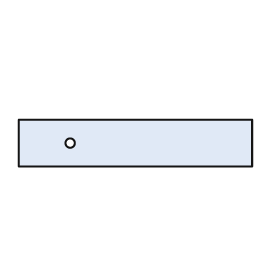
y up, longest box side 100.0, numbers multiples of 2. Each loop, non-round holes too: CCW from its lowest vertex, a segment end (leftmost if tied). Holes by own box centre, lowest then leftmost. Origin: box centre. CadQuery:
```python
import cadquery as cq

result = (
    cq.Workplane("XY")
    .moveTo(-50.0, -10.0)
    .lineTo(50.0, -10.0)
    .lineTo(50.0, 10.0)
    .lineTo(-50.0, 10.0)
    .close()
    .moveTo(-28.0, 0.0)
    .circle(2.0)
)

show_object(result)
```